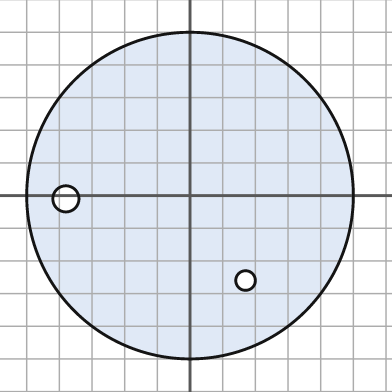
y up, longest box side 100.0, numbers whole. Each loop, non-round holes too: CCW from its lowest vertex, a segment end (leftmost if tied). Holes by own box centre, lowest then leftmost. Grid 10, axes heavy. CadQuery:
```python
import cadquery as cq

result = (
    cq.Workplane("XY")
    .moveTo(0.0, 0.0)
    .circle(50.0)
    .moveTo(17.0, -26.0)
    .circle(3.0)
    .moveTo(-38.0, -1.0)
    .circle(4.0)
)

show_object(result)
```